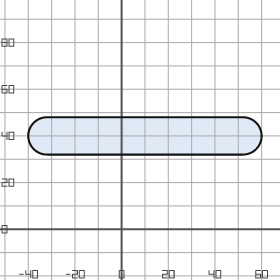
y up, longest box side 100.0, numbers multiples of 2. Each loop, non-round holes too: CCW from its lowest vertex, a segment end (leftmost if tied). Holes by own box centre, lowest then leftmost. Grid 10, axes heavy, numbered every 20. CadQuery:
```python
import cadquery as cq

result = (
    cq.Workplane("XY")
    .moveTo(-32.0, 32.0)
    .lineTo(52.0, 32.0)
    .threePointArc((60.0, 40.0), (52.0, 48.0))
    .lineTo(-32.0, 48.0)
    .threePointArc((-40.0, 40.0), (-32.0, 32.0))
    .close()
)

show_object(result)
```